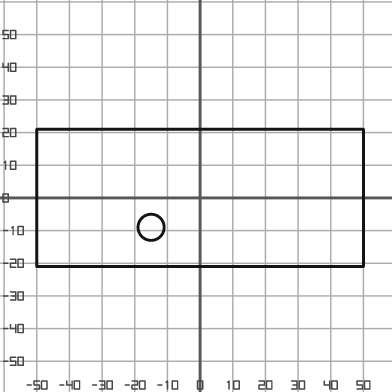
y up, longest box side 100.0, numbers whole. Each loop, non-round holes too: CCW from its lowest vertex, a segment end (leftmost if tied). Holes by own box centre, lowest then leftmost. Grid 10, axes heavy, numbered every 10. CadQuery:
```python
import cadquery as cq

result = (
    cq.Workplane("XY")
    .moveTo(-50.0, -21.0)
    .lineTo(50.0, -21.0)
    .lineTo(50.0, 21.0)
    .lineTo(-50.0, 21.0)
    .close()
    .moveTo(-15.0, -9.0)
    .circle(4.0)
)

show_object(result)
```